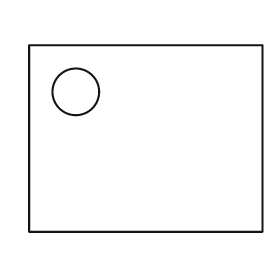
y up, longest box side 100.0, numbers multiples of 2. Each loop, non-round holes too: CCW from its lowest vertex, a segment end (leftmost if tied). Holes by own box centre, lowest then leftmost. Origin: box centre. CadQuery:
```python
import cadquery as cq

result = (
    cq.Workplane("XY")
    .moveTo(-50.0, -40.0)
    .lineTo(50.0, -40.0)
    .lineTo(50.0, 40.0)
    .lineTo(-50.0, 40.0)
    .close()
    .moveTo(-30.0, 20.0)
    .circle(10.0)
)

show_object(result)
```